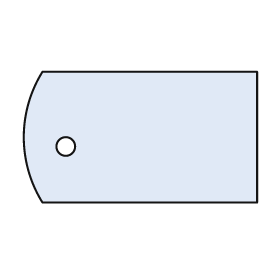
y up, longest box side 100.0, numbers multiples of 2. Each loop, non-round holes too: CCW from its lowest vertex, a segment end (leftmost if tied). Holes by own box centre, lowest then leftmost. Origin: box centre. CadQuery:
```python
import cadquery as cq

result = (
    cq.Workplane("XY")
    .moveTo(-42.0, -28.0)
    .lineTo(50.0, -28.0)
    .lineTo(50.0, 28.0)
    .lineTo(-42.0, 28.0)
    .threePointArc((-50.0, 0.0), (-42.0, -28.0))
    .close()
    .moveTo(-32.0, -4.0)
    .circle(4.0)
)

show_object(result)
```